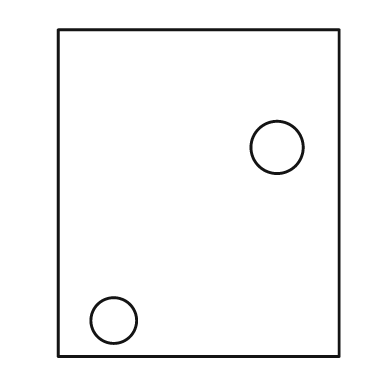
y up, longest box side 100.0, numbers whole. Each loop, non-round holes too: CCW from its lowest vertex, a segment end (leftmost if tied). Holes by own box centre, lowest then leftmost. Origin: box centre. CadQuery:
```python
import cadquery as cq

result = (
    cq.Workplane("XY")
    .moveTo(-43.0, -50.0)
    .lineTo(43.0, -50.0)
    .lineTo(43.0, 50.0)
    .lineTo(-43.0, 50.0)
    .close()
    .moveTo(-26.0, -39.0)
    .circle(7.0)
    .moveTo(24.0, 14.0)
    .circle(8.0)
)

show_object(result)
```